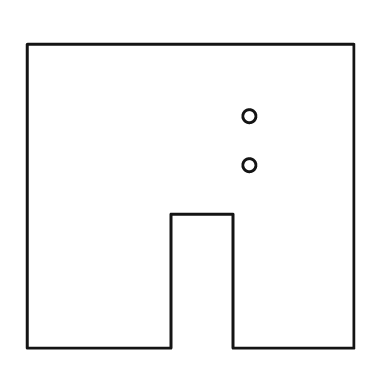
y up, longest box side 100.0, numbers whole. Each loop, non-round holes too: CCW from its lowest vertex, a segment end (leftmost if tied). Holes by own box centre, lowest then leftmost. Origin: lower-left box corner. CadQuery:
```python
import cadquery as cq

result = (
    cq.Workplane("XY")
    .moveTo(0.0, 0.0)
    .lineTo(44.0, 0.0)
    .lineTo(44.0, 41.0)
    .lineTo(63.0, 41.0)
    .lineTo(63.0, 0.0)
    .lineTo(100.0, 0.0)
    .lineTo(100.0, 93.0)
    .lineTo(0.0, 93.0)
    .close()
    .moveTo(68.0, 56.0)
    .circle(2.0)
    .moveTo(68.0, 71.0)
    .circle(2.0)
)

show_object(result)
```